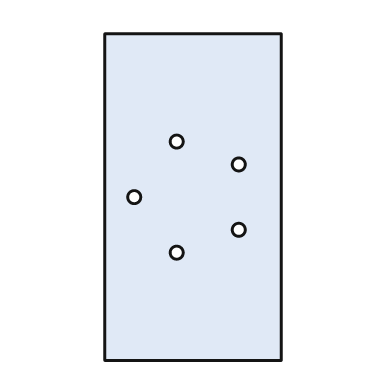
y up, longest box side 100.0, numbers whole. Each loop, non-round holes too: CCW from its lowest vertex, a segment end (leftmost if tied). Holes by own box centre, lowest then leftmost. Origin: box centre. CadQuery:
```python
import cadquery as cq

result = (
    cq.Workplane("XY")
    .moveTo(-27.0, -50.0)
    .lineTo(27.0, -50.0)
    .lineTo(27.0, 50.0)
    .lineTo(-27.0, 50.0)
    .close()
    .moveTo(-5.0, -17.0)
    .circle(2.0)
    .moveTo(14.0, -10.0)
    .circle(2.0)
    .moveTo(-18.0, 0.0)
    .circle(2.0)
    .moveTo(14.0, 10.0)
    .circle(2.0)
    .moveTo(-5.0, 17.0)
    .circle(2.0)
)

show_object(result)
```